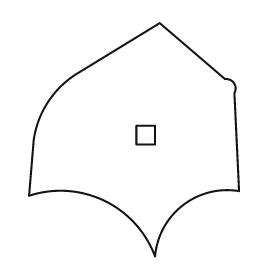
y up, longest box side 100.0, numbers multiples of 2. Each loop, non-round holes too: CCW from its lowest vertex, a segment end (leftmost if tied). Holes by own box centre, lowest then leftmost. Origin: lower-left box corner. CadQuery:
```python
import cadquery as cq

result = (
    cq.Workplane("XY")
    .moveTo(54.0, 0.0)
    .threePointArc((66.0, 22.0), (90.0, 28.0))
    .lineTo(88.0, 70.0)
    .threePointArc((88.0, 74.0), (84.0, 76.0))
    .lineTo(56.0, 100.0)
    .lineTo(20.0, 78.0)
    .threePointArc((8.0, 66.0), (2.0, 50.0))
    .lineTo(0.0, 26.0)
    .threePointArc((32.0, 24.0), (54.0, 0.0))
    .close()
    .moveTo(46.0, 48.0)
    .lineTo(54.0, 48.0)
    .lineTo(54.0, 56.0)
    .lineTo(46.0, 56.0)
    .close()
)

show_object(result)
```